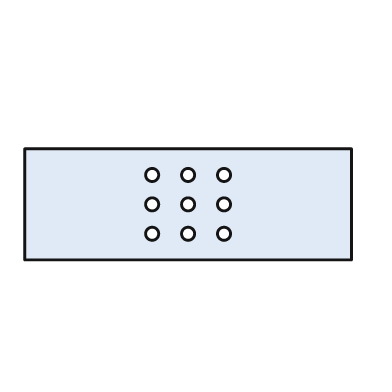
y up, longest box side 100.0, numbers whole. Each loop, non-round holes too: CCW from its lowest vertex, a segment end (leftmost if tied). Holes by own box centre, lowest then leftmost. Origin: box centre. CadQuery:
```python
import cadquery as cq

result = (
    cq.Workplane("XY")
    .moveTo(-50.0, -17.0)
    .lineTo(50.0, -17.0)
    .lineTo(50.0, 17.0)
    .lineTo(-50.0, 17.0)
    .close()
    .moveTo(-11.0, -9.0)
    .circle(2.0)
    .moveTo(0.0, -9.0)
    .circle(2.0)
    .moveTo(11.0, -9.0)
    .circle(2.0)
    .moveTo(-11.0, 0.0)
    .circle(2.0)
    .moveTo(0.0, 0.0)
    .circle(2.0)
    .moveTo(11.0, 0.0)
    .circle(2.0)
    .moveTo(-11.0, 9.0)
    .circle(2.0)
    .moveTo(0.0, 9.0)
    .circle(2.0)
    .moveTo(11.0, 9.0)
    .circle(2.0)
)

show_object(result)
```